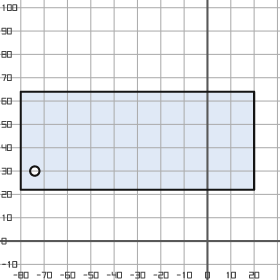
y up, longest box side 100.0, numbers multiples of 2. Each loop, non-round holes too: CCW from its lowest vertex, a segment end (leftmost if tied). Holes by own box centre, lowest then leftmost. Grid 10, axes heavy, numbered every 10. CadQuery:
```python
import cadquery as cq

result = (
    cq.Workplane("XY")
    .moveTo(-80.0, 22.0)
    .lineTo(20.0, 22.0)
    .lineTo(20.0, 64.0)
    .lineTo(-80.0, 64.0)
    .close()
    .moveTo(-74.0, 30.0)
    .circle(2.0)
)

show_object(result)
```